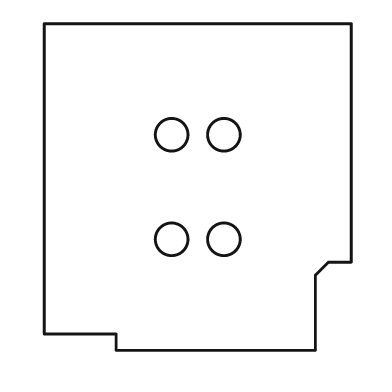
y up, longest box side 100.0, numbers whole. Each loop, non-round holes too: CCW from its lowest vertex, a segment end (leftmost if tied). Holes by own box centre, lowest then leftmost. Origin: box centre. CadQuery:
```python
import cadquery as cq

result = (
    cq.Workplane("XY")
    .moveTo(-25.0, -50.0)
    .lineTo(36.0, -50.0)
    .lineTo(36.0, -27.0)
    .lineTo(40.0, -23.0)
    .lineTo(47.0, -23.0)
    .lineTo(47.0, 50.0)
    .lineTo(-47.0, 50.0)
    .lineTo(-47.0, -45.0)
    .lineTo(-25.0, -45.0)
    .close()
    .moveTo(-8.0, -16.0)
    .circle(5.0)
    .moveTo(8.0, -16.0)
    .circle(5.0)
    .moveTo(-8.0, 16.0)
    .circle(5.0)
    .moveTo(8.0, 16.0)
    .circle(5.0)
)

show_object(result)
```